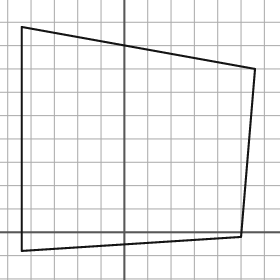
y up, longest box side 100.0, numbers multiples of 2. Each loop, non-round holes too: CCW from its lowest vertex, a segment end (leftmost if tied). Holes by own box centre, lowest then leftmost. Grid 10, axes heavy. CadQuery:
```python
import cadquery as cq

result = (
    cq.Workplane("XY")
    .moveTo(-44.0, -8.0)
    .lineTo(50.0, -2.0)
    .lineTo(56.0, 70.0)
    .lineTo(-44.0, 88.0)
    .close()
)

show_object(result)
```